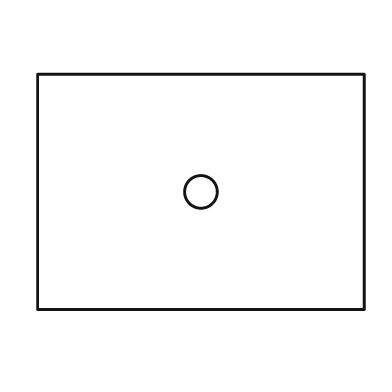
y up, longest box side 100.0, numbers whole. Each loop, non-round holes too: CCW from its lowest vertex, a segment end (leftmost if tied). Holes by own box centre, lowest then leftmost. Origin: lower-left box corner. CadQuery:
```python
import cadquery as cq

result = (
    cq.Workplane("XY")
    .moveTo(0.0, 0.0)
    .lineTo(100.0, 0.0)
    .lineTo(100.0, 72.0)
    .lineTo(0.0, 72.0)
    .close()
    .moveTo(50.0, 36.0)
    .circle(5.0)
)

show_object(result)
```